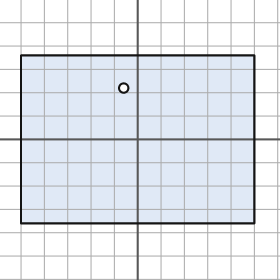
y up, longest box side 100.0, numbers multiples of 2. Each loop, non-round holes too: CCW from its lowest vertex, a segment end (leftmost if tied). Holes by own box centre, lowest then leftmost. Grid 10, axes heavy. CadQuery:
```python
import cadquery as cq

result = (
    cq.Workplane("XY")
    .moveTo(-50.0, -36.0)
    .lineTo(50.0, -36.0)
    .lineTo(50.0, 36.0)
    .lineTo(-50.0, 36.0)
    .close()
    .moveTo(-6.0, 22.0)
    .circle(2.0)
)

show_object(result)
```